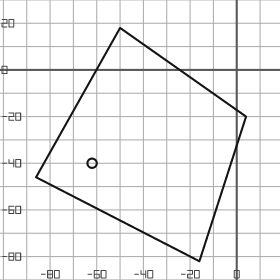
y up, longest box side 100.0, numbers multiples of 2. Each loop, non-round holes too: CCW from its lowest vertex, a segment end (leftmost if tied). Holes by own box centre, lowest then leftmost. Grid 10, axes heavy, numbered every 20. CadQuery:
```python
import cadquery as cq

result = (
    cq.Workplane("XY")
    .moveTo(-16.0, -82.0)
    .lineTo(4.0, -20.0)
    .lineTo(-50.0, 18.0)
    .lineTo(-86.0, -46.0)
    .close()
    .moveTo(-62.0, -40.0)
    .circle(2.0)
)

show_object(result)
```